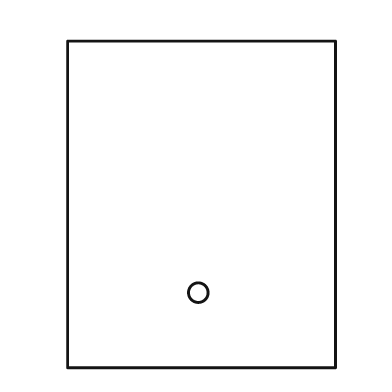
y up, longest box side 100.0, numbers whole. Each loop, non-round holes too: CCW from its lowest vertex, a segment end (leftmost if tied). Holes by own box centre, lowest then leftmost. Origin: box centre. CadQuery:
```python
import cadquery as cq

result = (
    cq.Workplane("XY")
    .moveTo(-41.0, -50.0)
    .lineTo(41.0, -50.0)
    .lineTo(41.0, 50.0)
    .lineTo(-41.0, 50.0)
    .close()
    .moveTo(-1.0, -27.0)
    .circle(3.0)
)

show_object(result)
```